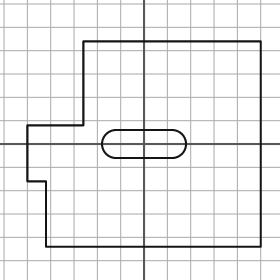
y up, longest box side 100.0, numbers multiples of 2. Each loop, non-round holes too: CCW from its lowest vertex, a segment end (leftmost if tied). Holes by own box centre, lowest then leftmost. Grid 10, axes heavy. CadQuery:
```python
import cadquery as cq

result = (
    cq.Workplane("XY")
    .moveTo(-42.0, -44.0)
    .lineTo(50.0, -44.0)
    .lineTo(50.0, 44.0)
    .lineTo(-26.0, 44.0)
    .lineTo(-26.0, 8.0)
    .lineTo(-50.0, 8.0)
    .lineTo(-50.0, -16.0)
    .lineTo(-42.0, -16.0)
    .close()
    .moveTo(-12.0, -6.0)
    .lineTo(12.0, -6.0)
    .threePointArc((18.0, 0.0), (12.0, 6.0))
    .lineTo(-12.0, 6.0)
    .threePointArc((-18.0, 0.0), (-12.0, -6.0))
    .close()
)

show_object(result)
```